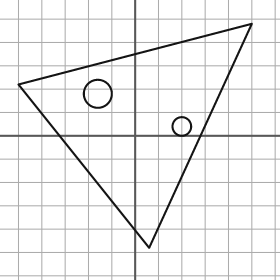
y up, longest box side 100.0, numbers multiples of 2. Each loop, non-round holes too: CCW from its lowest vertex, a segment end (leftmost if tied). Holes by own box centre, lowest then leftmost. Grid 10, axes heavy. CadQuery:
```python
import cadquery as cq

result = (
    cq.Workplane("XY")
    .moveTo(6.0, -48.0)
    .lineTo(50.0, 48.0)
    .lineTo(-50.0, 22.0)
    .close()
    .moveTo(20.0, 4.0)
    .circle(4.0)
    .moveTo(-16.0, 18.0)
    .circle(6.0)
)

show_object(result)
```